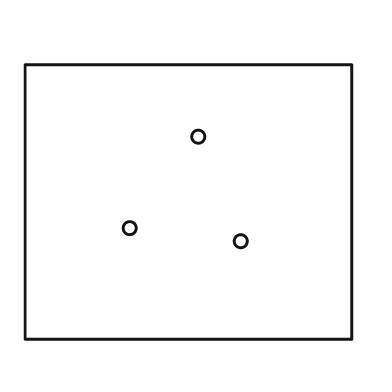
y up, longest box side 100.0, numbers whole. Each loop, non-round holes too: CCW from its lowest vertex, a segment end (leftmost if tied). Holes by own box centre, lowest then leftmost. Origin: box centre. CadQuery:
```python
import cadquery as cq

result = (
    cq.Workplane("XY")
    .moveTo(-50.0, -42.0)
    .lineTo(50.0, -42.0)
    .lineTo(50.0, 42.0)
    .lineTo(-50.0, 42.0)
    .close()
    .moveTo(16.0, -12.0)
    .circle(2.0)
    .moveTo(-18.0, -8.0)
    .circle(2.0)
    .moveTo(3.0, 20.0)
    .circle(2.0)
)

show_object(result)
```